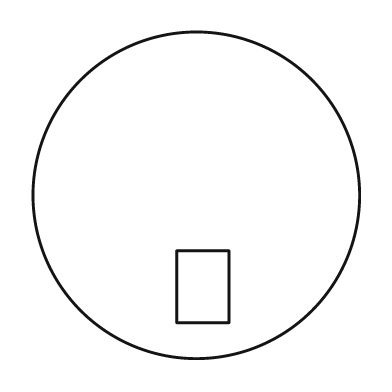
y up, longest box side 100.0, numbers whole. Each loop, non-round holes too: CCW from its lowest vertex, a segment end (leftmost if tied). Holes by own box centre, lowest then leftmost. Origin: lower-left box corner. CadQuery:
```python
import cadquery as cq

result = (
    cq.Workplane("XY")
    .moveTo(50.0, 50.0)
    .circle(50.0)
    .moveTo(44.0, 11.0)
    .lineTo(60.0, 11.0)
    .lineTo(60.0, 33.0)
    .lineTo(44.0, 33.0)
    .close()
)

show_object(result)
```